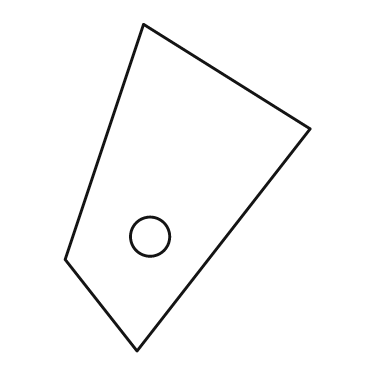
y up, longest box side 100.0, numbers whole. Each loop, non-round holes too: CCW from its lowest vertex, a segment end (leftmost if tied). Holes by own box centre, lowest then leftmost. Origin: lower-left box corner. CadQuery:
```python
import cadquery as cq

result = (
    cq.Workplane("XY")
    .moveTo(22.0, 0.0)
    .lineTo(75.0, 68.0)
    .lineTo(24.0, 100.0)
    .lineTo(0.0, 28.0)
    .close()
    .moveTo(26.0, 35.0)
    .circle(6.0)
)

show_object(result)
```